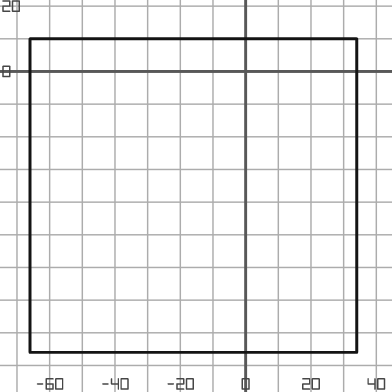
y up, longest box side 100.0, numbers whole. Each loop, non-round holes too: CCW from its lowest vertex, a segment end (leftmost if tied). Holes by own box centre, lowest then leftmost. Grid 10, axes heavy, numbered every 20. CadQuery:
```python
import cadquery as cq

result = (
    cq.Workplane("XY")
    .moveTo(-66.0, -86.0)
    .lineTo(34.0, -86.0)
    .lineTo(34.0, 10.0)
    .lineTo(-66.0, 10.0)
    .close()
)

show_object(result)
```